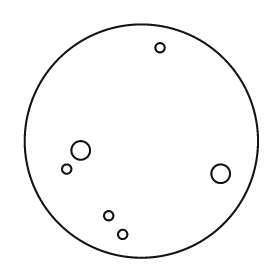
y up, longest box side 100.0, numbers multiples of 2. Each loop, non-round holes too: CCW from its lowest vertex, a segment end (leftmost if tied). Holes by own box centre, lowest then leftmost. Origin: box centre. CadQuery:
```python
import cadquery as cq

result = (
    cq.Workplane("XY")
    .moveTo(0.0, 0.0)
    .circle(50.0)
    .moveTo(-8.0, -40.0)
    .circle(2.0)
    .moveTo(-14.0, -32.0)
    .circle(2.0)
    .moveTo(34.0, -14.0)
    .circle(4.0)
    .moveTo(-32.0, -12.0)
    .circle(2.0)
    .moveTo(-26.0, -4.0)
    .circle(4.0)
    .moveTo(8.0, 40.0)
    .circle(2.0)
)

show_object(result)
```